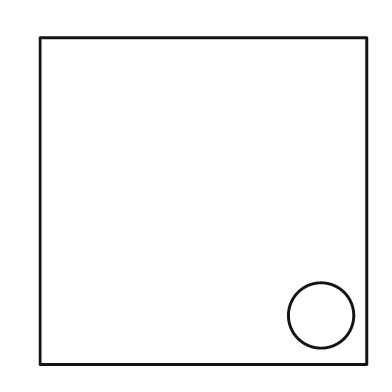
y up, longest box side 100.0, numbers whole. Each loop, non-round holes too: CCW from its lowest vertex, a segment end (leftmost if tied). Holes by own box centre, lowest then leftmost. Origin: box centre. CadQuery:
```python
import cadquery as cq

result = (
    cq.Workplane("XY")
    .moveTo(-50.0, -50.0)
    .lineTo(50.0, -50.0)
    .lineTo(50.0, 50.0)
    .lineTo(-50.0, 50.0)
    .close()
    .moveTo(36.0, -35.0)
    .circle(10.0)
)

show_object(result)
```